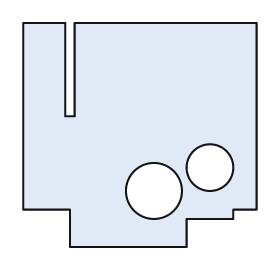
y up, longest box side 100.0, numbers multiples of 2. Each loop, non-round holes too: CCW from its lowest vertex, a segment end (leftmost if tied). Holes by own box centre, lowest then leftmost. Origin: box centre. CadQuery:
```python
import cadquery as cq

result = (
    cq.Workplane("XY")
    .moveTo(-30.0, -48.0)
    .lineTo(20.0, -48.0)
    .lineTo(20.0, -36.0)
    .lineTo(40.0, -36.0)
    .lineTo(40.0, -32.0)
    .lineTo(50.0, -32.0)
    .lineTo(50.0, 48.0)
    .lineTo(-28.0, 48.0)
    .lineTo(-28.0, 8.0)
    .lineTo(-32.0, 8.0)
    .lineTo(-32.0, 48.0)
    .lineTo(-50.0, 48.0)
    .lineTo(-50.0, -32.0)
    .lineTo(-30.0, -32.0)
    .close()
    .moveTo(6.0, -24.0)
    .circle(12.0)
    .moveTo(30.0, -14.0)
    .circle(10.0)
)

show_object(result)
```